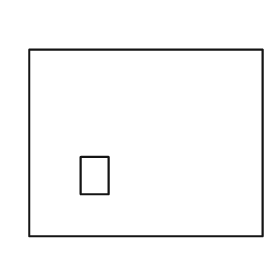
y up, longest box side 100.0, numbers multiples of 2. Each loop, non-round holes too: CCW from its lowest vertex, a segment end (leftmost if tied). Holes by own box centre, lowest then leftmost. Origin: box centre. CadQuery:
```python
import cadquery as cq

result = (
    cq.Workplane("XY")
    .moveTo(-50.0, -40.0)
    .lineTo(50.0, -40.0)
    .lineTo(50.0, 40.0)
    .lineTo(-50.0, 40.0)
    .close()
    .moveTo(-28.0, -22.0)
    .lineTo(-16.0, -22.0)
    .lineTo(-16.0, -6.0)
    .lineTo(-28.0, -6.0)
    .close()
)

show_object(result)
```